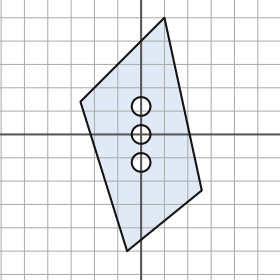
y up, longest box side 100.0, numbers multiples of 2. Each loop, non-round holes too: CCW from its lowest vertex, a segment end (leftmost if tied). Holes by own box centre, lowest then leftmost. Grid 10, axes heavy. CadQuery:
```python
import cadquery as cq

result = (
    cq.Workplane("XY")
    .moveTo(-6.0, -50.0)
    .lineTo(26.0, -24.0)
    .lineTo(10.0, 50.0)
    .lineTo(-26.0, 14.0)
    .close()
    .moveTo(0.0, -12.0)
    .circle(4.0)
    .moveTo(0.0, 0.0)
    .circle(4.0)
    .moveTo(0.0, 12.0)
    .circle(4.0)
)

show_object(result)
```